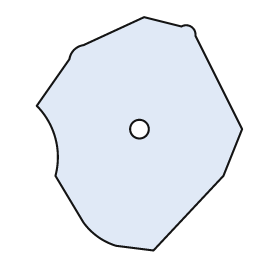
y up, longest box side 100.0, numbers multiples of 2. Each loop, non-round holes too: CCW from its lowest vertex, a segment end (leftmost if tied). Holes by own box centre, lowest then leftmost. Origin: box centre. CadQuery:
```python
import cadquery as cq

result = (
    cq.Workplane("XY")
    .moveTo(6.0, -50.0)
    .lineTo(36.0, -18.0)
    .lineTo(44.0, 2.0)
    .lineTo(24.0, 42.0)
    .threePointArc((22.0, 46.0), (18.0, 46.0))
    .lineTo(2.0, 50.0)
    .lineTo(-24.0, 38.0)
    .threePointArc((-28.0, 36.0), (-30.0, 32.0))
    .lineTo(-44.0, 12.0)
    .threePointArc((-36.0, -2.0), (-36.0, -18.0))
    .lineTo(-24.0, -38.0)
    .threePointArc((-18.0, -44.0), (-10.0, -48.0))
    .close()
    .moveTo(0.0, 2.0)
    .circle(4.0)
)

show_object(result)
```